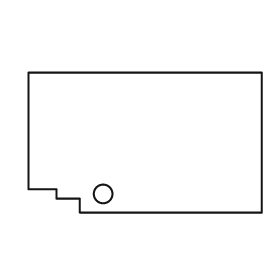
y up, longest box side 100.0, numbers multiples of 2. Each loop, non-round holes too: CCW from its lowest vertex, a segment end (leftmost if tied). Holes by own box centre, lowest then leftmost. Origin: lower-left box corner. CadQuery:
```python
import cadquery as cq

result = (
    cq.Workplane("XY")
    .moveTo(22.0, 0.0)
    .lineTo(100.0, 0.0)
    .lineTo(100.0, 60.0)
    .lineTo(0.0, 60.0)
    .lineTo(0.0, 10.0)
    .lineTo(12.0, 10.0)
    .lineTo(12.0, 6.0)
    .lineTo(22.0, 6.0)
    .close()
    .moveTo(32.0, 8.0)
    .circle(4.0)
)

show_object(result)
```